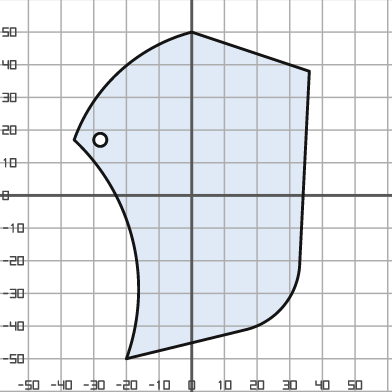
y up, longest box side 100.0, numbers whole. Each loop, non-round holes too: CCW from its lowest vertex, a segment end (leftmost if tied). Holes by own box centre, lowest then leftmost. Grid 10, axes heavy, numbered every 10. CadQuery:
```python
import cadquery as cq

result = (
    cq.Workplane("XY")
    .moveTo(-20.0, -50.0)
    .lineTo(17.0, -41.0)
    .threePointArc((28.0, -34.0), (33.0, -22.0))
    .lineTo(36.0, 38.0)
    .lineTo(0.0, 50.0)
    .threePointArc((-22.0, 38.0), (-36.0, 17.0))
    .threePointArc((-18.0, -14.0), (-20.0, -50.0))
    .close()
    .moveTo(-28.0, 17.0)
    .circle(2.0)
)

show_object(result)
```